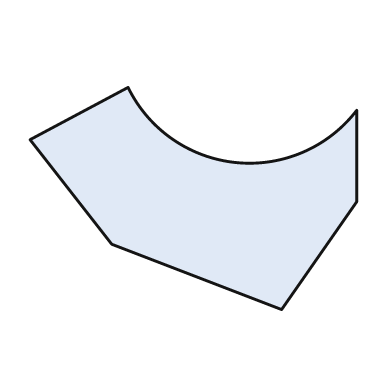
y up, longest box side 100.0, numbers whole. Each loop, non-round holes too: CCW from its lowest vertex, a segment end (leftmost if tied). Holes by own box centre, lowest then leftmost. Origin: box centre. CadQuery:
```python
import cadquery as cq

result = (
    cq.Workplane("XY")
    .moveTo(27.0, -34.0)
    .lineTo(50.0, -1.0)
    .lineTo(50.0, 27.0)
    .threePointArc((13.0, 11.0), (-20.0, 34.0))
    .lineTo(-50.0, 18.0)
    .lineTo(-25.0, -14.0)
    .close()
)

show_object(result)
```